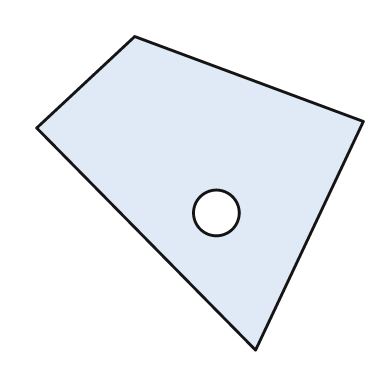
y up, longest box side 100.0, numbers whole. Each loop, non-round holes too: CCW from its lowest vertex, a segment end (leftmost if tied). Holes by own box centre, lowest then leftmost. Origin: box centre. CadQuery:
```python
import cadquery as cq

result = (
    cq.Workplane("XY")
    .moveTo(17.0, -48.0)
    .lineTo(50.0, 22.0)
    .lineTo(-20.0, 48.0)
    .lineTo(-50.0, 20.0)
    .close()
    .moveTo(5.0, -6.0)
    .circle(7.0)
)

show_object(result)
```